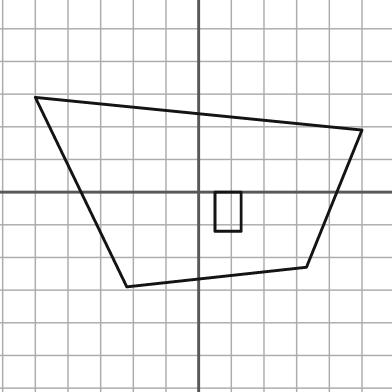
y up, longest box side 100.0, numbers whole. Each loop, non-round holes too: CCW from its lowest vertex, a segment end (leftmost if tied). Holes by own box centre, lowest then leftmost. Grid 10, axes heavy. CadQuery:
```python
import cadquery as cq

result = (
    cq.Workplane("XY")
    .moveTo(-22.0, -29.0)
    .lineTo(33.0, -23.0)
    .lineTo(50.0, 19.0)
    .lineTo(-50.0, 29.0)
    .close()
    .moveTo(5.0, -12.0)
    .lineTo(13.0, -12.0)
    .lineTo(13.0, 0.0)
    .lineTo(5.0, 0.0)
    .close()
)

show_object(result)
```